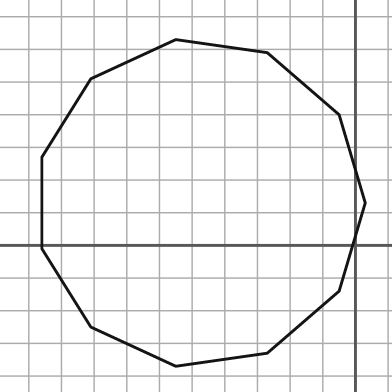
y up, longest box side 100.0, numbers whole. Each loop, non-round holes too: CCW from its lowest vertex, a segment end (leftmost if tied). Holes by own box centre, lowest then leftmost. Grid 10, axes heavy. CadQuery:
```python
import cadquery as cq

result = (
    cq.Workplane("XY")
    .moveTo(-55.0, -37.0)
    .lineTo(-27.0, -33.0)
    .lineTo(-5.0, -14.0)
    .lineTo(3.0, 13.0)
    .lineTo(-5.0, 40.0)
    .lineTo(-27.0, 59.0)
    .lineTo(-55.0, 63.0)
    .lineTo(-81.0, 51.0)
    .lineTo(-96.0, 27.0)
    .lineTo(-96.0, -1.0)
    .lineTo(-81.0, -25.0)
    .close()
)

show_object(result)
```